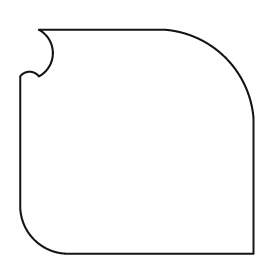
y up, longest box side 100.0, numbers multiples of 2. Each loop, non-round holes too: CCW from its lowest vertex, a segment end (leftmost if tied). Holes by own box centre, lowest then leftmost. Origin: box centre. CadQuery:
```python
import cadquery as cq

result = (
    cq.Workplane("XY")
    .moveTo(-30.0, -48.0)
    .lineTo(50.0, -48.0)
    .lineTo(50.0, 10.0)
    .threePointArc((38.0, 36.0), (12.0, 48.0))
    .lineTo(-42.0, 48.0)
    .threePointArc((-36.0, 38.0), (-42.0, 28.0))
    .threePointArc((-46.0, 30.0), (-50.0, 28.0))
    .lineTo(-50.0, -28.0)
    .threePointArc((-44.0, -42.0), (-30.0, -48.0))
    .close()
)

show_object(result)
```